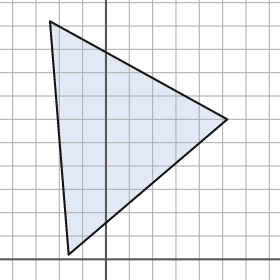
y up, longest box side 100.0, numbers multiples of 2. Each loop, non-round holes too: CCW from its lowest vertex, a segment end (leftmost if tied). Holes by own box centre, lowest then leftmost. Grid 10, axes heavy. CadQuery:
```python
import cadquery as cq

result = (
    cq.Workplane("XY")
    .moveTo(-16.0, 2.0)
    .lineTo(52.0, 60.0)
    .lineTo(-24.0, 102.0)
    .close()
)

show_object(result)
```